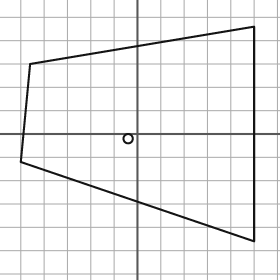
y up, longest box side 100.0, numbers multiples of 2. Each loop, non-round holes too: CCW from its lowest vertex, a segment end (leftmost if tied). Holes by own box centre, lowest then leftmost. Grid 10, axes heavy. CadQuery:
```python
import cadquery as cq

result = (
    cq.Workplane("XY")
    .moveTo(50.0, -46.0)
    .lineTo(50.0, 46.0)
    .lineTo(-46.0, 30.0)
    .lineTo(-50.0, -12.0)
    .close()
    .moveTo(-4.0, -2.0)
    .circle(2.0)
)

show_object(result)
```